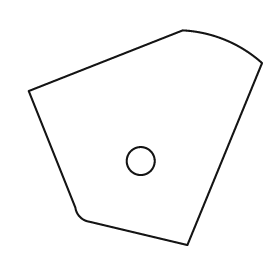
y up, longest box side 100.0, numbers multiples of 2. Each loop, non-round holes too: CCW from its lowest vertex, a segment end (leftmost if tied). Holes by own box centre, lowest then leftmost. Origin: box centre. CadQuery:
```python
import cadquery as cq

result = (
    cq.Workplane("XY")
    .moveTo(18.0, -46.0)
    .lineTo(50.0, 32.0)
    .threePointArc((34.0, 42.0), (16.0, 46.0))
    .lineTo(-50.0, 20.0)
    .lineTo(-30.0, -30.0)
    .threePointArc((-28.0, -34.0), (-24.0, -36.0))
    .close()
    .moveTo(-2.0, -10.0)
    .circle(6.0)
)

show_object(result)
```